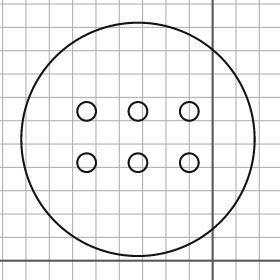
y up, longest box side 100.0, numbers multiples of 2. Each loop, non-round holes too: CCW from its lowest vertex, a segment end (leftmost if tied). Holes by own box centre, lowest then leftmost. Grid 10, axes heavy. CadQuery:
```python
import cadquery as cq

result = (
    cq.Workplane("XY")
    .moveTo(-32.0, 52.0)
    .circle(50.0)
    .moveTo(-54.0, 42.0)
    .circle(4.0)
    .moveTo(-32.0, 42.0)
    .circle(4.0)
    .moveTo(-10.0, 42.0)
    .circle(4.0)
    .moveTo(-54.0, 64.0)
    .circle(4.0)
    .moveTo(-32.0, 64.0)
    .circle(4.0)
    .moveTo(-10.0, 64.0)
    .circle(4.0)
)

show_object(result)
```